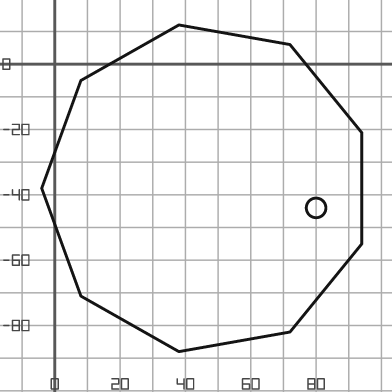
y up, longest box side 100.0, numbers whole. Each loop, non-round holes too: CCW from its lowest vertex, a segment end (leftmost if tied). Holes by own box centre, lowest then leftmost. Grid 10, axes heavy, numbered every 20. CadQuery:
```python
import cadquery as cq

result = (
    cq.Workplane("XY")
    .moveTo(38.0, -88.0)
    .lineTo(72.0, -82.0)
    .lineTo(94.0, -55.0)
    .lineTo(94.0, -21.0)
    .lineTo(72.0, 6.0)
    .lineTo(38.0, 12.0)
    .lineTo(8.0, -5.0)
    .lineTo(-4.0, -38.0)
    .lineTo(8.0, -71.0)
    .close()
    .moveTo(80.0, -44.0)
    .circle(3.0)
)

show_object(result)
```